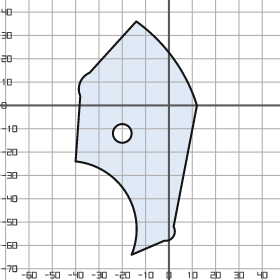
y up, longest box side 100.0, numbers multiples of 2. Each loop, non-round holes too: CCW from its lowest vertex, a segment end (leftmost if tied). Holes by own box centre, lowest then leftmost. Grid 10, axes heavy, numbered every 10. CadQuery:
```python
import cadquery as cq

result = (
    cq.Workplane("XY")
    .moveTo(-16.0, -64.0)
    .lineTo(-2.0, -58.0)
    .threePointArc((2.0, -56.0), (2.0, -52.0))
    .lineTo(12.0, 0.0)
    .threePointArc((2.0, 20.0), (-14.0, 36.0))
    .lineTo(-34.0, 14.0)
    .threePointArc((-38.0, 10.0), (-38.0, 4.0))
    .lineTo(-40.0, -24.0)
    .threePointArc((-18.0, -38.0), (-16.0, -64.0))
    .close()
    .moveTo(-20.0, -12.0)
    .circle(4.0)
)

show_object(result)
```